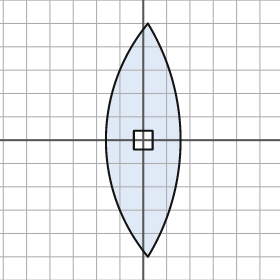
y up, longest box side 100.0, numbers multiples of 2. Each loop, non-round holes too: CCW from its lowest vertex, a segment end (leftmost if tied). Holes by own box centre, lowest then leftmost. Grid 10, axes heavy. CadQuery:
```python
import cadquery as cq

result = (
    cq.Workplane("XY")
    .moveTo(2.0, -50.0)
    .threePointArc((16.0, 0.0), (2.0, 50.0))
    .threePointArc((-16.0, 0.0), (2.0, -50.0))
    .close()
    .moveTo(-4.0, -4.0)
    .lineTo(4.0, -4.0)
    .lineTo(4.0, 4.0)
    .lineTo(-4.0, 4.0)
    .close()
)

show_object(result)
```